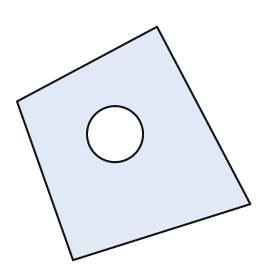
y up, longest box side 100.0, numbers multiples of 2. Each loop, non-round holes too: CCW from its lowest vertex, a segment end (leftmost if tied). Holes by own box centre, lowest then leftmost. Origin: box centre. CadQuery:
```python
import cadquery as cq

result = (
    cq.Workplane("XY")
    .moveTo(-26.0, -50.0)
    .lineTo(50.0, -26.0)
    .lineTo(10.0, 50.0)
    .lineTo(-50.0, 18.0)
    .close()
    .moveTo(-8.0, 4.0)
    .circle(12.0)
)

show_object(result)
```